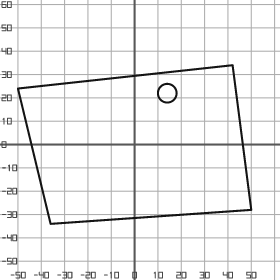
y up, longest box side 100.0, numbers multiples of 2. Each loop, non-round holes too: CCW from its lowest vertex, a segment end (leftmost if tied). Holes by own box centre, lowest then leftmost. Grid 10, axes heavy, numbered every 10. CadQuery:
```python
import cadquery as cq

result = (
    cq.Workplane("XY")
    .moveTo(-36.0, -34.0)
    .lineTo(50.0, -28.0)
    .lineTo(42.0, 34.0)
    .lineTo(-50.0, 24.0)
    .close()
    .moveTo(14.0, 22.0)
    .circle(4.0)
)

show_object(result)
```